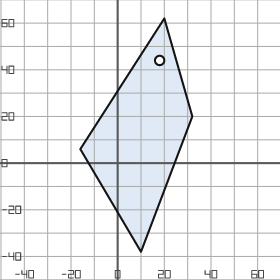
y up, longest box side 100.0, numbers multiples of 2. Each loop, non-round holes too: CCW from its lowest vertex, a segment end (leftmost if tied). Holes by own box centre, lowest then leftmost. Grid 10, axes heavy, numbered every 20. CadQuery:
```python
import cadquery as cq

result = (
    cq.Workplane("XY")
    .moveTo(10.0, -38.0)
    .lineTo(32.0, 20.0)
    .lineTo(20.0, 62.0)
    .lineTo(-16.0, 6.0)
    .close()
    .moveTo(18.0, 44.0)
    .circle(2.0)
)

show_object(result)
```